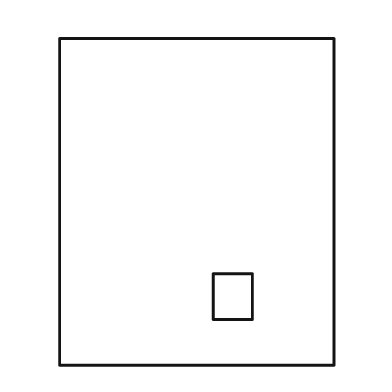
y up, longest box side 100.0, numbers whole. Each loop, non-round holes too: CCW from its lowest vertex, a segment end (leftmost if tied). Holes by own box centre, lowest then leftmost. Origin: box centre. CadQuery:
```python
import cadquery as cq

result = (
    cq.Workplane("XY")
    .moveTo(-42.0, -50.0)
    .lineTo(42.0, -50.0)
    .lineTo(42.0, 50.0)
    .lineTo(-42.0, 50.0)
    .close()
    .moveTo(5.0, -36.0)
    .lineTo(17.0, -36.0)
    .lineTo(17.0, -22.0)
    .lineTo(5.0, -22.0)
    .close()
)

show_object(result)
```